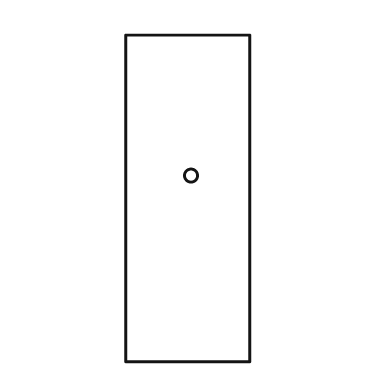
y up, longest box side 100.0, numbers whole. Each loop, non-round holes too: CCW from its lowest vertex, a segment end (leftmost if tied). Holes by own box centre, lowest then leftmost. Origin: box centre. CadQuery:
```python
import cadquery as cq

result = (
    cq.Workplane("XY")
    .moveTo(-19.0, -50.0)
    .lineTo(19.0, -50.0)
    .lineTo(19.0, 50.0)
    .lineTo(-19.0, 50.0)
    .close()
    .moveTo(1.0, 7.0)
    .circle(2.0)
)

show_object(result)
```